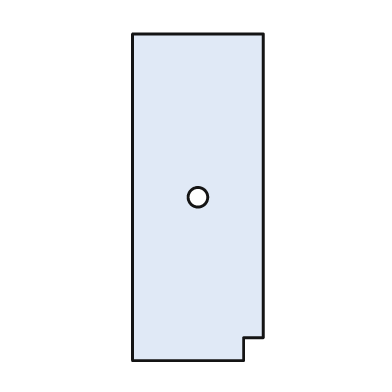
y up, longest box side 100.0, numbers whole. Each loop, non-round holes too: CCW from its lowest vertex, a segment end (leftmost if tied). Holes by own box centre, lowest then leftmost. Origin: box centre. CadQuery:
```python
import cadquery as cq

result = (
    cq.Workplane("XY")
    .moveTo(-20.0, -50.0)
    .lineTo(14.0, -50.0)
    .lineTo(14.0, -43.0)
    .lineTo(20.0, -43.0)
    .lineTo(20.0, 50.0)
    .lineTo(-20.0, 50.0)
    .close()
    .moveTo(0.0, 0.0)
    .circle(3.0)
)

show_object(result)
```